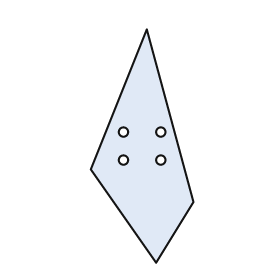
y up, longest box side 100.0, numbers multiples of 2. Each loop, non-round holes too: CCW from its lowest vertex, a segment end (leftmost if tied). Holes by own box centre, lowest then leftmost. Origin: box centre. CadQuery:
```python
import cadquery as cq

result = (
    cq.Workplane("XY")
    .moveTo(6.0, -50.0)
    .lineTo(22.0, -24.0)
    .lineTo(2.0, 50.0)
    .lineTo(-22.0, -10.0)
    .close()
    .moveTo(-8.0, -6.0)
    .circle(2.0)
    .moveTo(8.0, -6.0)
    .circle(2.0)
    .moveTo(-8.0, 6.0)
    .circle(2.0)
    .moveTo(8.0, 6.0)
    .circle(2.0)
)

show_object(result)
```